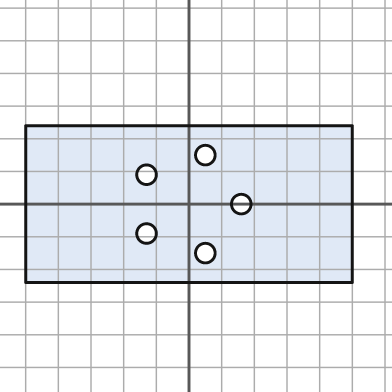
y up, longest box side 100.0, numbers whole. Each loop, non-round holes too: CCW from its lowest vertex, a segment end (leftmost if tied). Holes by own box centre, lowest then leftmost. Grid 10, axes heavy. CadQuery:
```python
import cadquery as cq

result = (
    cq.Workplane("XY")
    .moveTo(-50.0, -24.0)
    .lineTo(50.0, -24.0)
    .lineTo(50.0, 24.0)
    .lineTo(-50.0, 24.0)
    .close()
    .moveTo(5.0, -15.0)
    .circle(3.0)
    .moveTo(-13.0, -9.0)
    .circle(3.0)
    .moveTo(16.0, 0.0)
    .circle(3.0)
    .moveTo(-13.0, 9.0)
    .circle(3.0)
    .moveTo(5.0, 15.0)
    .circle(3.0)
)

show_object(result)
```